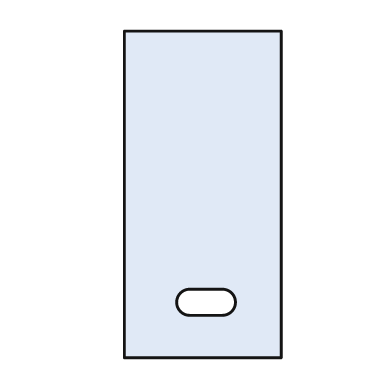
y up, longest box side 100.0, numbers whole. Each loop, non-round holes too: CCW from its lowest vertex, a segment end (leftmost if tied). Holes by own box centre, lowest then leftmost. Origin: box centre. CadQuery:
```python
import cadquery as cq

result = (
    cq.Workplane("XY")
    .moveTo(-24.0, -50.0)
    .lineTo(24.0, -50.0)
    .lineTo(24.0, 50.0)
    .lineTo(-24.0, 50.0)
    .close()
    .moveTo(-4.0, -37.0)
    .lineTo(6.0, -37.0)
    .threePointArc((10.0, -33.0), (6.0, -29.0))
    .lineTo(-4.0, -29.0)
    .threePointArc((-8.0, -33.0), (-4.0, -37.0))
    .close()
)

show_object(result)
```